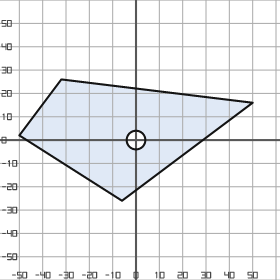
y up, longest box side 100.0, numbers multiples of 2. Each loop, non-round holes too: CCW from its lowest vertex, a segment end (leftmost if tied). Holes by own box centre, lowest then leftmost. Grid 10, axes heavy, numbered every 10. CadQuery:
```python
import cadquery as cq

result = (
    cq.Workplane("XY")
    .moveTo(-6.0, -26.0)
    .lineTo(50.0, 16.0)
    .lineTo(-32.0, 26.0)
    .lineTo(-50.0, 2.0)
    .close()
    .moveTo(0.0, 0.0)
    .circle(4.0)
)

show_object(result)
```